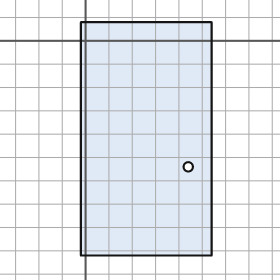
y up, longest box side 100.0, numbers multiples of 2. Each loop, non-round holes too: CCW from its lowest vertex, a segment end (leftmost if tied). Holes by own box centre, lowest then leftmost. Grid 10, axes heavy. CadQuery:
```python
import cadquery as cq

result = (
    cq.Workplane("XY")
    .moveTo(-2.0, -92.0)
    .lineTo(54.0, -92.0)
    .lineTo(54.0, 8.0)
    .lineTo(-2.0, 8.0)
    .close()
    .moveTo(44.0, -54.0)
    .circle(2.0)
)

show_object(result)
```